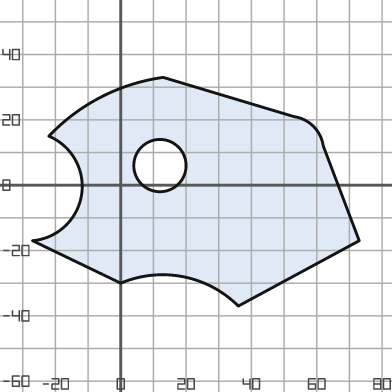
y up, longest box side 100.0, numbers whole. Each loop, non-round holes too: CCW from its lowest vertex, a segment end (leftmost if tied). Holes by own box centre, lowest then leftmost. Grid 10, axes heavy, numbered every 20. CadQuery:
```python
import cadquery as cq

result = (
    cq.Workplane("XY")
    .moveTo(36.0, -37.0)
    .lineTo(73.0, -17.0)
    .lineTo(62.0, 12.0)
    .threePointArc((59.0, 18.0), (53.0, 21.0))
    .lineTo(13.0, 33.0)
    .threePointArc((-6.0, 27.0), (-22.0, 15.0))
    .threePointArc((-12.0, -3.0), (-27.0, -17.0))
    .lineTo(0.0, -30.0)
    .threePointArc((19.0, -28.0), (36.0, -37.0))
    .close()
    .moveTo(12.0, 6.0)
    .circle(8.0)
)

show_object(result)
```